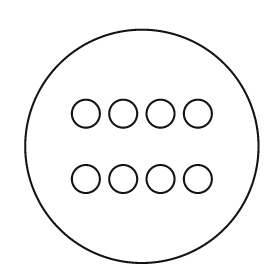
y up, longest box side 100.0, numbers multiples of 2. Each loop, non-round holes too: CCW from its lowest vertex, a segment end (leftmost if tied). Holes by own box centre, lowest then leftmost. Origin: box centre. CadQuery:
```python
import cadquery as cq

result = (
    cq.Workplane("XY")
    .moveTo(0.0, 0.0)
    .circle(50.0)
    .moveTo(-24.0, -14.0)
    .circle(6.0)
    .moveTo(-8.0, -14.0)
    .circle(6.0)
    .moveTo(8.0, -14.0)
    .circle(6.0)
    .moveTo(24.0, -14.0)
    .circle(6.0)
    .moveTo(-24.0, 14.0)
    .circle(6.0)
    .moveTo(-8.0, 14.0)
    .circle(6.0)
    .moveTo(8.0, 14.0)
    .circle(6.0)
    .moveTo(24.0, 14.0)
    .circle(6.0)
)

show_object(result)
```